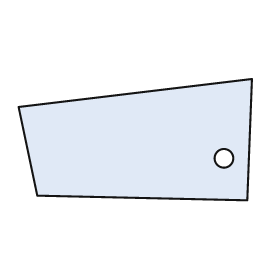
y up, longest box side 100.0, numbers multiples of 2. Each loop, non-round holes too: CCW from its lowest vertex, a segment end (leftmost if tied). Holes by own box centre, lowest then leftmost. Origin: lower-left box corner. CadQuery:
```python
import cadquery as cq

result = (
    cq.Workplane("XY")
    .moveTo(98.0, 0.0)
    .lineTo(100.0, 52.0)
    .lineTo(0.0, 40.0)
    .lineTo(8.0, 2.0)
    .close()
    .moveTo(88.0, 18.0)
    .circle(4.0)
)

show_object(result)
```